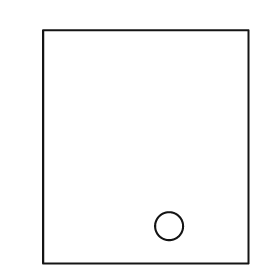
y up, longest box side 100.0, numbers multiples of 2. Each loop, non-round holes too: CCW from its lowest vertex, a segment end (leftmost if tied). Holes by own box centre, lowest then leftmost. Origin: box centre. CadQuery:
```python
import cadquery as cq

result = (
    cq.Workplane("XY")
    .moveTo(-44.0, -50.0)
    .lineTo(44.0, -50.0)
    .lineTo(44.0, 50.0)
    .lineTo(-44.0, 50.0)
    .close()
    .moveTo(10.0, -34.0)
    .circle(6.0)
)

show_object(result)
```